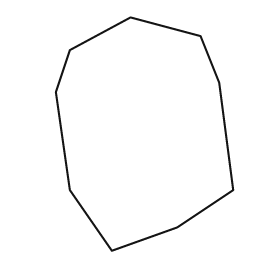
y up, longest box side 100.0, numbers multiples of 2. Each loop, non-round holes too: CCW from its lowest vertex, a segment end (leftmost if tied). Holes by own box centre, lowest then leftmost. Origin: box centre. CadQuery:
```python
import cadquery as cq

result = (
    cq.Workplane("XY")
    .moveTo(-14.0, -50.0)
    .lineTo(14.0, -40.0)
    .lineTo(38.0, -24.0)
    .lineTo(32.0, 22.0)
    .lineTo(24.0, 42.0)
    .lineTo(-6.0, 50.0)
    .lineTo(-32.0, 36.0)
    .lineTo(-38.0, 18.0)
    .lineTo(-32.0, -24.0)
    .close()
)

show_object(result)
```